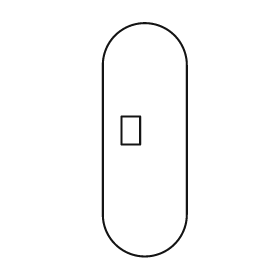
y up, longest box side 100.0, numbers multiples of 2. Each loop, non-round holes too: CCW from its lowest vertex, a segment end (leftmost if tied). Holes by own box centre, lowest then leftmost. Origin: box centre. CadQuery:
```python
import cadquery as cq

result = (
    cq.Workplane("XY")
    .moveTo(-18.0, -32.0)
    .threePointArc((0.0, -50.0), (18.0, -32.0))
    .lineTo(18.0, 32.0)
    .threePointArc((0.0, 50.0), (-18.0, 32.0))
    .close()
    .moveTo(-10.0, -2.0)
    .lineTo(-2.0, -2.0)
    .lineTo(-2.0, 10.0)
    .lineTo(-10.0, 10.0)
    .close()
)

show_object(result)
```